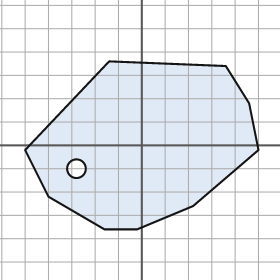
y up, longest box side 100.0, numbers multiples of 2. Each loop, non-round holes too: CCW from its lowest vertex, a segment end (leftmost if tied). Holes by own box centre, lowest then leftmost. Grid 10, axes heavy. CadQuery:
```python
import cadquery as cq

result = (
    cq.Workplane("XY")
    .moveTo(-16.0, -36.0)
    .lineTo(-2.0, -36.0)
    .lineTo(22.0, -26.0)
    .lineTo(50.0, -2.0)
    .lineTo(46.0, 18.0)
    .lineTo(36.0, 34.0)
    .lineTo(-14.0, 36.0)
    .lineTo(-50.0, -2.0)
    .lineTo(-40.0, -22.0)
    .close()
    .moveTo(-28.0, -10.0)
    .circle(4.0)
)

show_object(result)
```